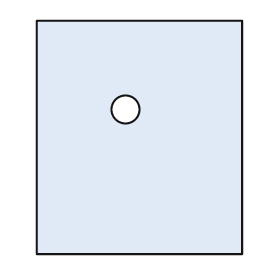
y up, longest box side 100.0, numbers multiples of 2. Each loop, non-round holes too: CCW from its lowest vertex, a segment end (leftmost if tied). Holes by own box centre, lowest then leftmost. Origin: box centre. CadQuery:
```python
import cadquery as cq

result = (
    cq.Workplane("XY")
    .moveTo(-44.0, -50.0)
    .lineTo(44.0, -50.0)
    .lineTo(44.0, 50.0)
    .lineTo(-44.0, 50.0)
    .close()
    .moveTo(-6.0, 12.0)
    .circle(6.0)
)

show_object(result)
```